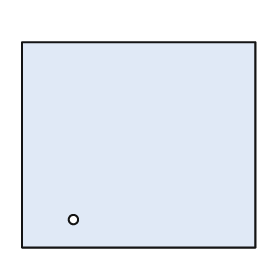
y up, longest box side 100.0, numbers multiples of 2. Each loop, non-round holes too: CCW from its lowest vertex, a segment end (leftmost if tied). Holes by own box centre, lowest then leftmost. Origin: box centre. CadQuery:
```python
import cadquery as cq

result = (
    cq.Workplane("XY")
    .moveTo(-50.0, -44.0)
    .lineTo(50.0, -44.0)
    .lineTo(50.0, 44.0)
    .lineTo(-50.0, 44.0)
    .close()
    .moveTo(-28.0, -32.0)
    .circle(2.0)
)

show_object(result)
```